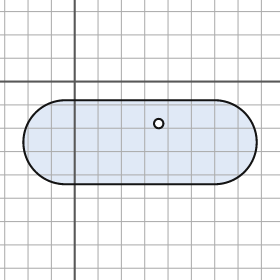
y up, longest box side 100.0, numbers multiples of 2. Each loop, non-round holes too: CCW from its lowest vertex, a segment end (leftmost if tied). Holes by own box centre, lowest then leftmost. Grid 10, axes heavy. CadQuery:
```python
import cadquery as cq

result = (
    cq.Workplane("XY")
    .moveTo(-4.0, -44.0)
    .lineTo(60.0, -44.0)
    .threePointArc((78.0, -26.0), (60.0, -8.0))
    .lineTo(-4.0, -8.0)
    .threePointArc((-22.0, -26.0), (-4.0, -44.0))
    .close()
    .moveTo(36.0, -18.0)
    .circle(2.0)
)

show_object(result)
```